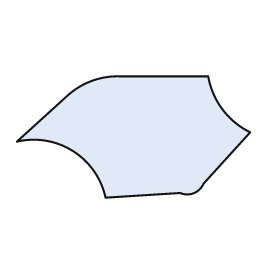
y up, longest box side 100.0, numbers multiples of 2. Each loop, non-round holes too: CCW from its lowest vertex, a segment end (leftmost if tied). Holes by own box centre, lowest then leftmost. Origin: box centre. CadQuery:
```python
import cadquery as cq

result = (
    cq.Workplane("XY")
    .moveTo(-12.0, -26.0)
    .lineTo(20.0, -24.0)
    .threePointArc((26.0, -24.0), (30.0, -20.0))
    .lineTo(50.0, 2.0)
    .threePointArc((38.0, 12.0), (32.0, 26.0))
    .lineTo(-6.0, 26.0)
    .threePointArc((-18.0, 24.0), (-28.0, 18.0))
    .lineTo(-50.0, -2.0)
    .threePointArc((-26.0, -6.0), (-12.0, -26.0))
    .close()
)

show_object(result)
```